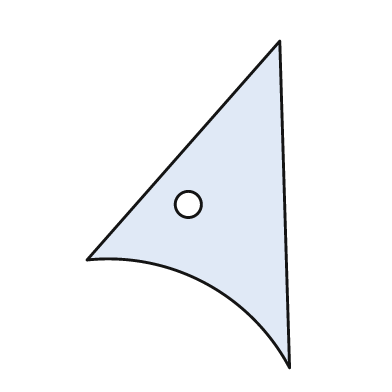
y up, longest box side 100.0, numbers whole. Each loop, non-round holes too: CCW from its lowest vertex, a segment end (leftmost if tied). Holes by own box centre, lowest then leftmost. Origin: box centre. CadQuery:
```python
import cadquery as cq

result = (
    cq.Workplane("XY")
    .moveTo(31.0, -50.0)
    .lineTo(28.0, 50.0)
    .lineTo(-31.0, -17.0)
    .threePointArc((5.0, -24.0), (31.0, -50.0))
    .close()
    .moveTo(0.0, 0.0)
    .circle(4.0)
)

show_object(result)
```